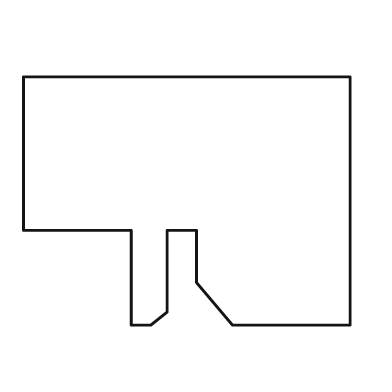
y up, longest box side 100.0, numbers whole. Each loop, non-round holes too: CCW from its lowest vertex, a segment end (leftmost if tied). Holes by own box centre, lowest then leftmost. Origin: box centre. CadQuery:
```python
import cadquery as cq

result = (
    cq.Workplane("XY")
    .moveTo(-17.0, -38.0)
    .lineTo(-11.0, -38.0)
    .lineTo(-6.0, -34.0)
    .lineTo(-6.0, -9.0)
    .lineTo(3.0, -9.0)
    .lineTo(3.0, -25.0)
    .lineTo(14.0, -38.0)
    .lineTo(50.0, -38.0)
    .lineTo(50.0, 38.0)
    .lineTo(-50.0, 38.0)
    .lineTo(-50.0, -9.0)
    .lineTo(-17.0, -9.0)
    .close()
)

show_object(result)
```